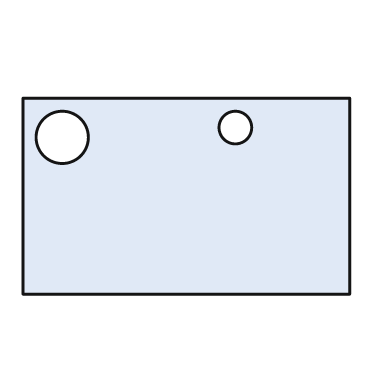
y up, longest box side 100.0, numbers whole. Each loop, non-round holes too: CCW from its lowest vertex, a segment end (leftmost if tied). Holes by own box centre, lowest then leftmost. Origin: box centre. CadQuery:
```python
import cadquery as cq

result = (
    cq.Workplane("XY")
    .moveTo(-50.0, -30.0)
    .lineTo(50.0, -30.0)
    .lineTo(50.0, 30.0)
    .lineTo(-50.0, 30.0)
    .close()
    .moveTo(-38.0, 18.0)
    .circle(8.0)
    .moveTo(15.0, 21.0)
    .circle(5.0)
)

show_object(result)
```